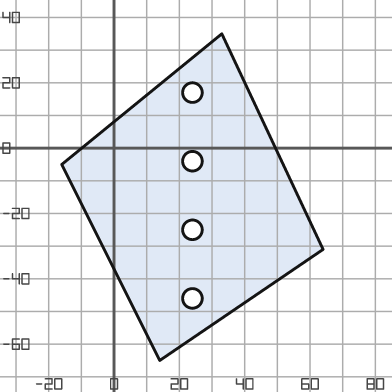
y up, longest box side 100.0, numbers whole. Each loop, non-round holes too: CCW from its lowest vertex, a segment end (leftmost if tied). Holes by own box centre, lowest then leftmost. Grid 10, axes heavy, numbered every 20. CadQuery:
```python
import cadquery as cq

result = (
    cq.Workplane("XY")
    .moveTo(14.0, -65.0)
    .lineTo(64.0, -31.0)
    .lineTo(33.0, 35.0)
    .lineTo(-16.0, -5.0)
    .close()
    .moveTo(24.0, -46.0)
    .circle(3.0)
    .moveTo(24.0, -25.0)
    .circle(3.0)
    .moveTo(24.0, -4.0)
    .circle(3.0)
    .moveTo(24.0, 17.0)
    .circle(3.0)
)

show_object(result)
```